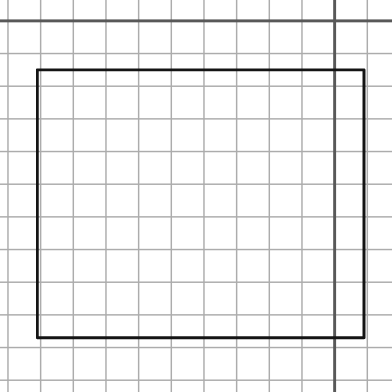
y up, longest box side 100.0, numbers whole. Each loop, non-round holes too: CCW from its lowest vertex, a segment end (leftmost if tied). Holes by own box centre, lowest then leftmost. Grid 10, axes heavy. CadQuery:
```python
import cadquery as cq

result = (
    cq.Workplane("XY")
    .moveTo(-91.0, -97.0)
    .lineTo(9.0, -97.0)
    .lineTo(9.0, -15.0)
    .lineTo(-91.0, -15.0)
    .close()
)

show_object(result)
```